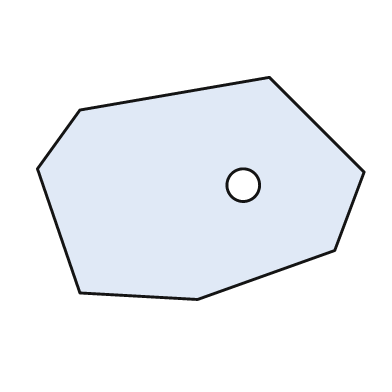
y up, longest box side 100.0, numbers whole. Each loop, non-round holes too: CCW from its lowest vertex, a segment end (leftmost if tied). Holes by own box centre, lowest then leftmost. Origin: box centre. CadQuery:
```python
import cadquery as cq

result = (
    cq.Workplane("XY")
    .moveTo(-1.0, -34.0)
    .lineTo(41.0, -19.0)
    .lineTo(50.0, 5.0)
    .lineTo(21.0, 34.0)
    .lineTo(-37.0, 24.0)
    .lineTo(-50.0, 6.0)
    .lineTo(-37.0, -32.0)
    .close()
    .moveTo(13.0, 1.0)
    .circle(5.0)
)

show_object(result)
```